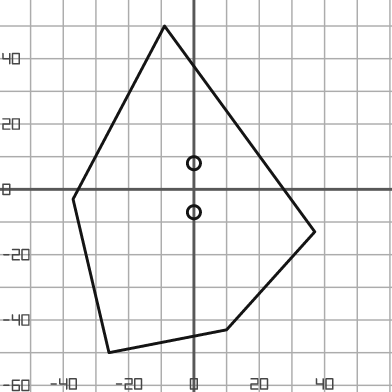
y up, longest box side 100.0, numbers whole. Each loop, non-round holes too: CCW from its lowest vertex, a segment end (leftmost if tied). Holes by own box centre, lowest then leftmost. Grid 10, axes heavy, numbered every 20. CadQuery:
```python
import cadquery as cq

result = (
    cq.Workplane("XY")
    .moveTo(-26.0, -50.0)
    .lineTo(10.0, -43.0)
    .lineTo(37.0, -13.0)
    .lineTo(-9.0, 50.0)
    .lineTo(-37.0, -3.0)
    .close()
    .moveTo(0.0, -7.0)
    .circle(2.0)
    .moveTo(0.0, 8.0)
    .circle(2.0)
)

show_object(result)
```